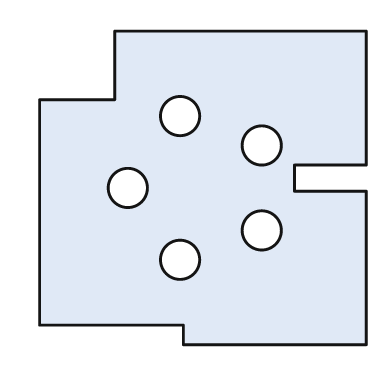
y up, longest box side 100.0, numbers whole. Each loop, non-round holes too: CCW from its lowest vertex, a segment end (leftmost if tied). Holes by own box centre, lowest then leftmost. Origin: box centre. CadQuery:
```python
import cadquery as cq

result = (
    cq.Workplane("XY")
    .moveTo(-6.0, -48.0)
    .lineTo(50.0, -48.0)
    .lineTo(50.0, -1.0)
    .lineTo(28.0, -1.0)
    .lineTo(28.0, 7.0)
    .lineTo(50.0, 7.0)
    .lineTo(50.0, 48.0)
    .lineTo(-27.0, 48.0)
    .lineTo(-27.0, 27.0)
    .lineTo(-50.0, 27.0)
    .lineTo(-50.0, -42.0)
    .lineTo(-6.0, -42.0)
    .close()
    .moveTo(-7.0, -22.0)
    .circle(6.0)
    .moveTo(18.0, -13.0)
    .circle(6.0)
    .moveTo(-23.0, 0.0)
    .circle(6.0)
    .moveTo(18.0, 13.0)
    .circle(6.0)
    .moveTo(-7.0, 22.0)
    .circle(6.0)
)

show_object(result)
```